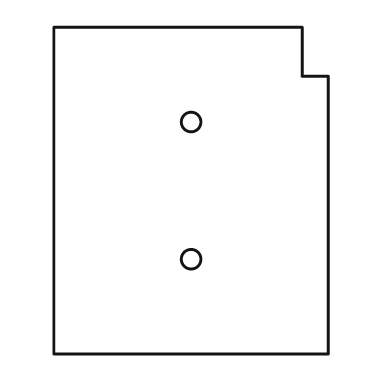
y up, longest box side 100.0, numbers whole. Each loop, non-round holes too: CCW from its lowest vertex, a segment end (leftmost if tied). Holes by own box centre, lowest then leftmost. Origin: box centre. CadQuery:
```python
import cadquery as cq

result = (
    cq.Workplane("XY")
    .moveTo(-42.0, -50.0)
    .lineTo(42.0, -50.0)
    .lineTo(42.0, 35.0)
    .lineTo(34.0, 35.0)
    .lineTo(34.0, 50.0)
    .lineTo(-42.0, 50.0)
    .close()
    .moveTo(0.0, -21.0)
    .circle(3.0)
    .moveTo(0.0, 21.0)
    .circle(3.0)
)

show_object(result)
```